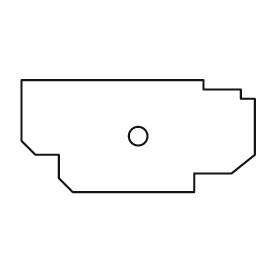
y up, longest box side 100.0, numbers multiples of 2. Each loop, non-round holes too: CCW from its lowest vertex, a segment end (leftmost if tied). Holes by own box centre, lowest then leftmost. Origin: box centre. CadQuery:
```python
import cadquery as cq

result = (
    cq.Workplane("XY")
    .moveTo(-28.0, -24.0)
    .lineTo(24.0, -24.0)
    .lineTo(24.0, -16.0)
    .lineTo(40.0, -16.0)
    .lineTo(50.0, -8.0)
    .lineTo(50.0, 16.0)
    .lineTo(44.0, 16.0)
    .lineTo(44.0, 20.0)
    .lineTo(28.0, 20.0)
    .lineTo(28.0, 24.0)
    .lineTo(-50.0, 24.0)
    .lineTo(-50.0, -2.0)
    .lineTo(-44.0, -8.0)
    .lineTo(-34.0, -8.0)
    .lineTo(-34.0, -18.0)
    .close()
    .moveTo(0.0, 0.0)
    .circle(4.0)
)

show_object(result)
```